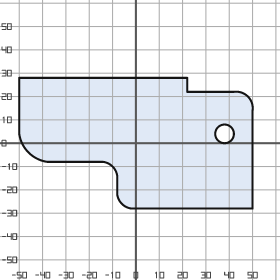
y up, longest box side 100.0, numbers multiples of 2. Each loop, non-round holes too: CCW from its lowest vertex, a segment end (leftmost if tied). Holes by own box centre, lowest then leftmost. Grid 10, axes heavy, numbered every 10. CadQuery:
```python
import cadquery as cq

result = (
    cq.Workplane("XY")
    .moveTo(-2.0, -28.0)
    .lineTo(50.0, -28.0)
    .lineTo(50.0, 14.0)
    .threePointArc((48.0, 20.0), (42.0, 22.0))
    .lineTo(22.0, 22.0)
    .lineTo(22.0, 28.0)
    .lineTo(-50.0, 28.0)
    .lineTo(-50.0, 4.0)
    .threePointArc((-46.0, -4.0), (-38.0, -8.0))
    .lineTo(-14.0, -8.0)
    .threePointArc((-10.0, -10.0), (-8.0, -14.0))
    .lineTo(-8.0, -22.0)
    .threePointArc((-6.0, -26.0), (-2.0, -28.0))
    .close()
    .moveTo(38.0, 4.0)
    .circle(4.0)
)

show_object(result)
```